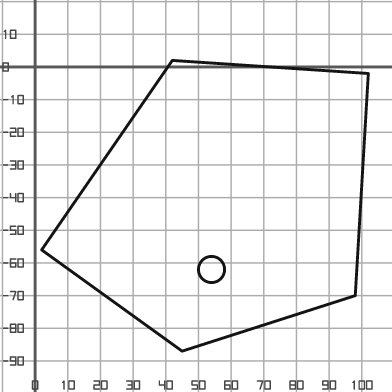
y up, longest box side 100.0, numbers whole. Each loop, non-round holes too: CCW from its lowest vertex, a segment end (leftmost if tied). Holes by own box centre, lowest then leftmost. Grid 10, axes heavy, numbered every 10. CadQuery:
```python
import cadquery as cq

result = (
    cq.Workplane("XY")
    .moveTo(45.0, -87.0)
    .lineTo(98.0, -70.0)
    .lineTo(102.0, -2.0)
    .lineTo(42.0, 2.0)
    .lineTo(2.0, -56.0)
    .close()
    .moveTo(54.0, -62.0)
    .circle(4.0)
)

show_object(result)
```